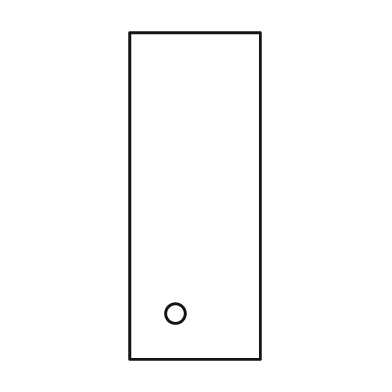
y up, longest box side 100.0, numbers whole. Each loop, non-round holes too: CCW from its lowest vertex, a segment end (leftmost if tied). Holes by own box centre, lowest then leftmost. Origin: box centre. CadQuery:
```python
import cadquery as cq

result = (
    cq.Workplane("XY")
    .moveTo(-20.0, -50.0)
    .lineTo(20.0, -50.0)
    .lineTo(20.0, 50.0)
    .lineTo(-20.0, 50.0)
    .close()
    .moveTo(-6.0, -36.0)
    .circle(3.0)
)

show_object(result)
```